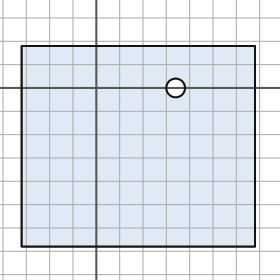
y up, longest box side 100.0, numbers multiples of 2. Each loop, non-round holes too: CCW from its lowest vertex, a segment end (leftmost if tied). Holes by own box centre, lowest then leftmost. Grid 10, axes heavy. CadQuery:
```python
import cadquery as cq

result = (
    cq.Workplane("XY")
    .moveTo(-32.0, -68.0)
    .lineTo(68.0, -68.0)
    .lineTo(68.0, 18.0)
    .lineTo(-32.0, 18.0)
    .close()
    .moveTo(34.0, 0.0)
    .circle(4.0)
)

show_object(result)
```